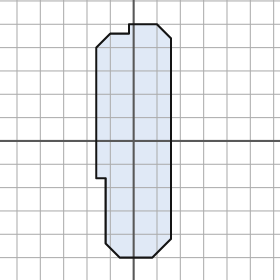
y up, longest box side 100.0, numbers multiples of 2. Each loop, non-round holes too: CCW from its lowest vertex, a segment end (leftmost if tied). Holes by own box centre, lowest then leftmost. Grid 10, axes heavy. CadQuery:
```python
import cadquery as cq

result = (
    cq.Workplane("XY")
    .moveTo(-6.0, -50.0)
    .lineTo(8.0, -50.0)
    .lineTo(16.0, -42.0)
    .lineTo(16.0, 44.0)
    .lineTo(10.0, 50.0)
    .lineTo(-2.0, 50.0)
    .lineTo(-2.0, 46.0)
    .lineTo(-10.0, 46.0)
    .lineTo(-16.0, 40.0)
    .lineTo(-16.0, -16.0)
    .lineTo(-12.0, -16.0)
    .lineTo(-12.0, -44.0)
    .close()
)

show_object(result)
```